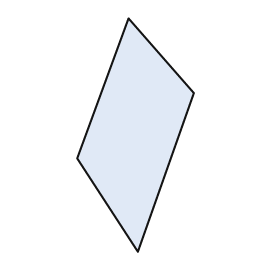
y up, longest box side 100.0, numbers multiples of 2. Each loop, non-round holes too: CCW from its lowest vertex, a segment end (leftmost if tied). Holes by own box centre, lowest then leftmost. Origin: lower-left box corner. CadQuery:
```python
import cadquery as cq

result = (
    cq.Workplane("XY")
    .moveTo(26.0, 0.0)
    .lineTo(50.0, 68.0)
    .lineTo(22.0, 100.0)
    .lineTo(0.0, 40.0)
    .close()
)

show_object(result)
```